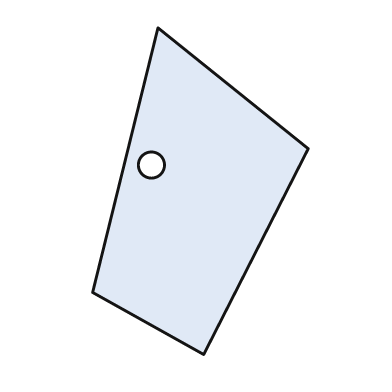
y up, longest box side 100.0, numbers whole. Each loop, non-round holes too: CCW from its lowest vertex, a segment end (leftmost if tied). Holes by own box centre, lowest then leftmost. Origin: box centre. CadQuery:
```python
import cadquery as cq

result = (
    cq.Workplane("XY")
    .moveTo(1.0, -50.0)
    .lineTo(33.0, 13.0)
    .lineTo(-13.0, 50.0)
    .lineTo(-33.0, -31.0)
    .close()
    .moveTo(-15.0, 8.0)
    .circle(4.0)
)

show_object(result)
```